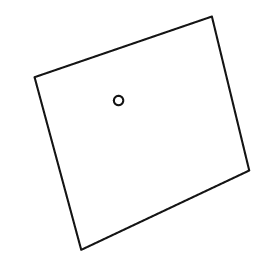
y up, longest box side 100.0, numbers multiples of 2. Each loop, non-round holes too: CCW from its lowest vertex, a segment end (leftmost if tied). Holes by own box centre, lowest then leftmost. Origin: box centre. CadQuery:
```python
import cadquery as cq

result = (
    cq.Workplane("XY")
    .moveTo(-26.0, -50.0)
    .lineTo(46.0, -16.0)
    .lineTo(30.0, 50.0)
    .lineTo(-46.0, 24.0)
    .close()
    .moveTo(-10.0, 14.0)
    .circle(2.0)
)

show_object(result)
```